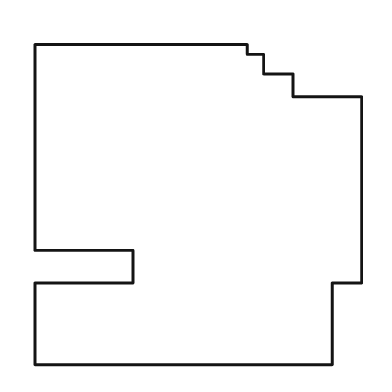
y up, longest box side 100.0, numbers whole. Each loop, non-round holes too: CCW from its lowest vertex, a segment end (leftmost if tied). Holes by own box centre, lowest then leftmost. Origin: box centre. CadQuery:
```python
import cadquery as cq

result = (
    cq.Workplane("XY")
    .moveTo(-50.0, -49.0)
    .lineTo(41.0, -49.0)
    .lineTo(41.0, -24.0)
    .lineTo(50.0, -24.0)
    .lineTo(50.0, 33.0)
    .lineTo(29.0, 33.0)
    .lineTo(29.0, 40.0)
    .lineTo(20.0, 40.0)
    .lineTo(20.0, 46.0)
    .lineTo(15.0, 46.0)
    .lineTo(15.0, 49.0)
    .lineTo(-50.0, 49.0)
    .lineTo(-50.0, -14.0)
    .lineTo(-20.0, -14.0)
    .lineTo(-20.0, -24.0)
    .lineTo(-50.0, -24.0)
    .close()
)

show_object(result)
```